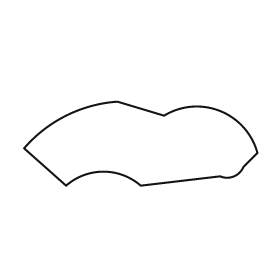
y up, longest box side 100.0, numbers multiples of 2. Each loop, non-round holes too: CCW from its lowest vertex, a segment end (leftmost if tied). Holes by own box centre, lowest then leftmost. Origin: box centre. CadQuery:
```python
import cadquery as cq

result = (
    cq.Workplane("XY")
    .moveTo(-32.0, -18.0)
    .threePointArc((-16.0, -12.0), (0.0, -18.0))
    .lineTo(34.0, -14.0)
    .threePointArc((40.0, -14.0), (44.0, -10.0))
    .lineTo(50.0, -4.0)
    .threePointArc((34.0, 14.0), (10.0, 12.0))
    .lineTo(-10.0, 18.0)
    .threePointArc((-32.0, 12.0), (-50.0, -2.0))
    .close()
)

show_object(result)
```